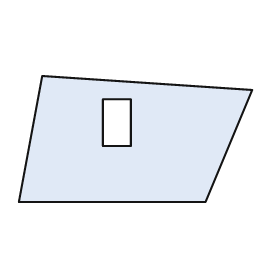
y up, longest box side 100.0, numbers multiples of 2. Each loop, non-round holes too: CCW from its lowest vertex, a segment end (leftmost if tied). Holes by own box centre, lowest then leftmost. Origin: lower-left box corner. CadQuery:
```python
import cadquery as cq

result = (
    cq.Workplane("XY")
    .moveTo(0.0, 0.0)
    .lineTo(80.0, 0.0)
    .lineTo(100.0, 48.0)
    .lineTo(10.0, 54.0)
    .close()
    .moveTo(36.0, 24.0)
    .lineTo(48.0, 24.0)
    .lineTo(48.0, 44.0)
    .lineTo(36.0, 44.0)
    .close()
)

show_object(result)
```